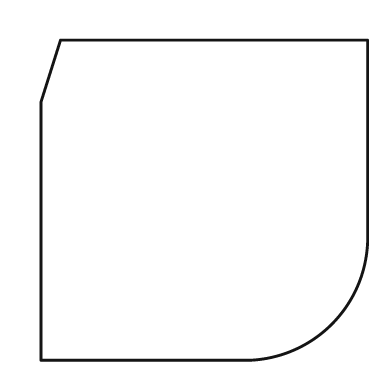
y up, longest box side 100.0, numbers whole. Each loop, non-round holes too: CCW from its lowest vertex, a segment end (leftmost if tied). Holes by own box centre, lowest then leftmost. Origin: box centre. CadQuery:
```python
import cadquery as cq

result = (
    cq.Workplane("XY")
    .moveTo(-50.0, -49.0)
    .lineTo(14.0, -49.0)
    .threePointArc((39.0, -38.0), (50.0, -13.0))
    .lineTo(50.0, 49.0)
    .lineTo(-44.0, 49.0)
    .lineTo(-50.0, 30.0)
    .close()
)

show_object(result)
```